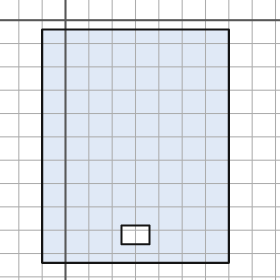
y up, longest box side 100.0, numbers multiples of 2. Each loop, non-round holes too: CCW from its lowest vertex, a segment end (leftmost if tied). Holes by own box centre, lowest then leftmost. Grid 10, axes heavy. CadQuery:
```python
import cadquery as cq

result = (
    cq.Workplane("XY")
    .moveTo(-10.0, -104.0)
    .lineTo(70.0, -104.0)
    .lineTo(70.0, -4.0)
    .lineTo(-10.0, -4.0)
    .close()
    .moveTo(24.0, -96.0)
    .lineTo(36.0, -96.0)
    .lineTo(36.0, -88.0)
    .lineTo(24.0, -88.0)
    .close()
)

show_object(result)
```